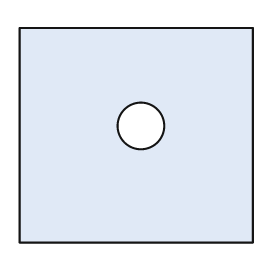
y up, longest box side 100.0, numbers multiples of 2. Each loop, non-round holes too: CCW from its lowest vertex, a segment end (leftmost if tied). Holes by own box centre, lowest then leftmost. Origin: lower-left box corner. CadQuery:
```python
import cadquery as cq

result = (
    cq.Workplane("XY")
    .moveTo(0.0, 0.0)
    .lineTo(100.0, 0.0)
    .lineTo(100.0, 92.0)
    .lineTo(0.0, 92.0)
    .close()
    .moveTo(52.0, 50.0)
    .circle(10.0)
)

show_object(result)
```